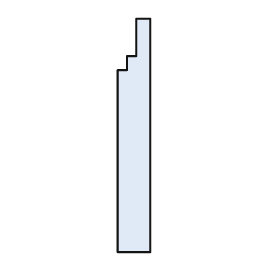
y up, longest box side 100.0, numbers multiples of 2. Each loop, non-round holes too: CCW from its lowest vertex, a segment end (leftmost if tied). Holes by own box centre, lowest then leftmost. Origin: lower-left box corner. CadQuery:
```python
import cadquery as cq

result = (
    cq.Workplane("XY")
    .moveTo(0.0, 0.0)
    .lineTo(14.0, 0.0)
    .lineTo(14.0, 100.0)
    .lineTo(8.0, 100.0)
    .lineTo(8.0, 84.0)
    .lineTo(4.0, 84.0)
    .lineTo(4.0, 78.0)
    .lineTo(0.0, 78.0)
    .close()
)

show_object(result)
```